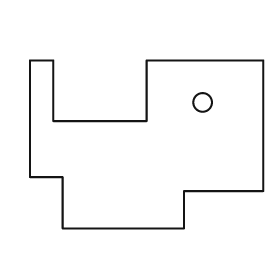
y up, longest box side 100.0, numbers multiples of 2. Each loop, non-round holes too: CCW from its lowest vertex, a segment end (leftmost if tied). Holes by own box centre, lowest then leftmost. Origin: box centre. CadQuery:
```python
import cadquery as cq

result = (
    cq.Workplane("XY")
    .moveTo(-36.0, -36.0)
    .lineTo(16.0, -36.0)
    .lineTo(16.0, -20.0)
    .lineTo(50.0, -20.0)
    .lineTo(50.0, 36.0)
    .lineTo(0.0, 36.0)
    .lineTo(0.0, 10.0)
    .lineTo(-40.0, 10.0)
    .lineTo(-40.0, 36.0)
    .lineTo(-50.0, 36.0)
    .lineTo(-50.0, -14.0)
    .lineTo(-36.0, -14.0)
    .close()
    .moveTo(24.0, 18.0)
    .circle(4.0)
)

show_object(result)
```